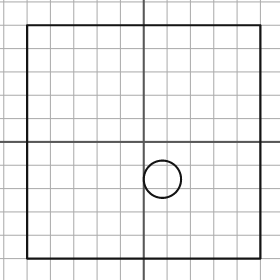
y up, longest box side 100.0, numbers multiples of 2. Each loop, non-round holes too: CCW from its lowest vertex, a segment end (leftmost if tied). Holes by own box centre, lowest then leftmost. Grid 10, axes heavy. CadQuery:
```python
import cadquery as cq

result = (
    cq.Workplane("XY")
    .moveTo(-50.0, -50.0)
    .lineTo(50.0, -50.0)
    .lineTo(50.0, 50.0)
    .lineTo(-50.0, 50.0)
    .close()
    .moveTo(8.0, -16.0)
    .circle(8.0)
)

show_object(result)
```